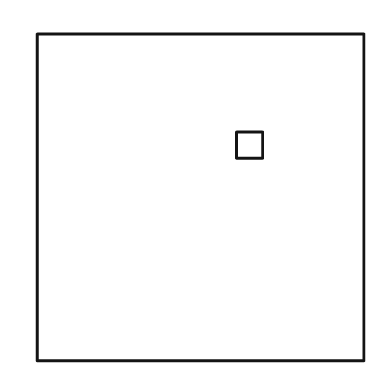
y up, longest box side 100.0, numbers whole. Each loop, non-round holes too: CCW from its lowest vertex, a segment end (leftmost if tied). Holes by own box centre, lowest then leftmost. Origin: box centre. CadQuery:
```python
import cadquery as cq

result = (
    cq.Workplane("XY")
    .moveTo(-50.0, -50.0)
    .lineTo(50.0, -50.0)
    .lineTo(50.0, 50.0)
    .lineTo(-50.0, 50.0)
    .close()
    .moveTo(11.0, 12.0)
    .lineTo(19.0, 12.0)
    .lineTo(19.0, 20.0)
    .lineTo(11.0, 20.0)
    .close()
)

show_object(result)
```